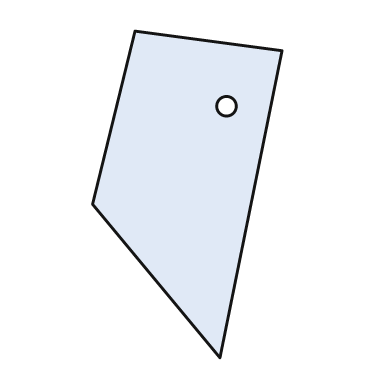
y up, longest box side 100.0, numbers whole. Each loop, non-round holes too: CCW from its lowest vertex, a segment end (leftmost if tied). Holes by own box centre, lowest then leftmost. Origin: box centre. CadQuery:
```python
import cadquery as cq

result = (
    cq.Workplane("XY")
    .moveTo(10.0, -50.0)
    .lineTo(29.0, 44.0)
    .lineTo(-16.0, 50.0)
    .lineTo(-29.0, -3.0)
    .close()
    .moveTo(12.0, 27.0)
    .circle(3.0)
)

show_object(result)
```